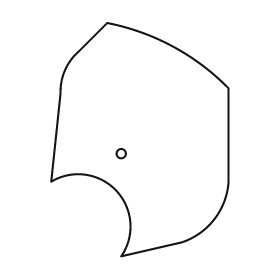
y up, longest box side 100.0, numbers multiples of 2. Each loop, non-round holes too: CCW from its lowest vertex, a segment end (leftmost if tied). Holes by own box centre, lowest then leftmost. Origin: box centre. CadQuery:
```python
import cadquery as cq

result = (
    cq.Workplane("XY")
    .moveTo(-8.0, -50.0)
    .lineTo(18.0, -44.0)
    .threePointArc((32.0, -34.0), (38.0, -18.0))
    .lineTo(38.0, 22.0)
    .threePointArc((14.0, 40.0), (-14.0, 50.0))
    .lineTo(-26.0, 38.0)
    .threePointArc((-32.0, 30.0), (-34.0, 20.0))
    .lineTo(-38.0, -18.0)
    .threePointArc((-10.0, -22.0), (-8.0, -50.0))
    .close()
    .moveTo(-8.0, -6.0)
    .circle(2.0)
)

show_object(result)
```